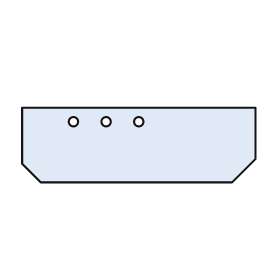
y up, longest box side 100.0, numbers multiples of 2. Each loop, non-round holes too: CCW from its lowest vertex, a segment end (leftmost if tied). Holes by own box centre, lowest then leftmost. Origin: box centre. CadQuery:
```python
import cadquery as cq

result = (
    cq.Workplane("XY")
    .moveTo(-42.0, -16.0)
    .lineTo(40.0, -16.0)
    .lineTo(50.0, -6.0)
    .lineTo(50.0, 16.0)
    .lineTo(-50.0, 16.0)
    .lineTo(-50.0, -8.0)
    .close()
    .moveTo(-28.0, 10.0)
    .circle(2.0)
    .moveTo(-14.0, 10.0)
    .circle(2.0)
    .moveTo(0.0, 10.0)
    .circle(2.0)
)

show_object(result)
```